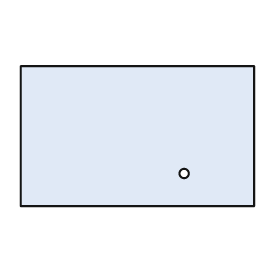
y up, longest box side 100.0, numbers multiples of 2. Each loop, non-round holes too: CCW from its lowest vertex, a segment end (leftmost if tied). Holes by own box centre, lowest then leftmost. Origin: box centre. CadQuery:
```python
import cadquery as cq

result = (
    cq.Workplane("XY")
    .moveTo(-50.0, -30.0)
    .lineTo(50.0, -30.0)
    .lineTo(50.0, 30.0)
    .lineTo(-50.0, 30.0)
    .close()
    .moveTo(20.0, -16.0)
    .circle(2.0)
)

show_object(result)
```